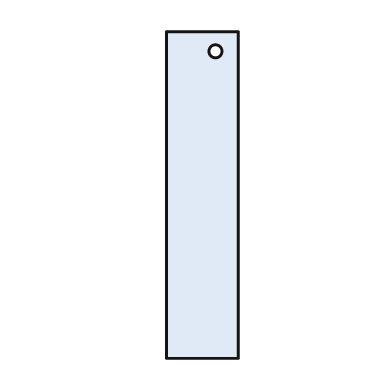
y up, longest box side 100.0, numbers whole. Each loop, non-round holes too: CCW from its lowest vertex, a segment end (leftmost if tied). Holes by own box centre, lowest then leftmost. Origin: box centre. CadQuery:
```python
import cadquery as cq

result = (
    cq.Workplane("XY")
    .moveTo(-11.0, -50.0)
    .lineTo(11.0, -50.0)
    .lineTo(11.0, 50.0)
    .lineTo(-11.0, 50.0)
    .close()
    .moveTo(4.0, 44.0)
    .circle(2.0)
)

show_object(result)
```